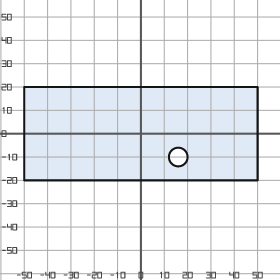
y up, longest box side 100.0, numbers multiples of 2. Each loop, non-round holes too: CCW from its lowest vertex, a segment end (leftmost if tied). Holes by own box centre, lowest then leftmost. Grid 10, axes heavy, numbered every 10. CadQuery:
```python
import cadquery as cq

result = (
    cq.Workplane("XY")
    .moveTo(-50.0, -20.0)
    .lineTo(50.0, -20.0)
    .lineTo(50.0, 20.0)
    .lineTo(-50.0, 20.0)
    .close()
    .moveTo(16.0, -10.0)
    .circle(4.0)
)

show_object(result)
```